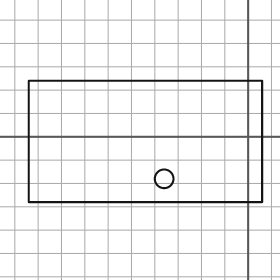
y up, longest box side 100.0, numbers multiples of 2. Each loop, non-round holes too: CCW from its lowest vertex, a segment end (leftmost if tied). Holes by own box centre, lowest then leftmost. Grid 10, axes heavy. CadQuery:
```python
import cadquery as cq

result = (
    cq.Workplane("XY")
    .moveTo(-94.0, -28.0)
    .lineTo(6.0, -28.0)
    .lineTo(6.0, 24.0)
    .lineTo(-94.0, 24.0)
    .close()
    .moveTo(-36.0, -18.0)
    .circle(4.0)
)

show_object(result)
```